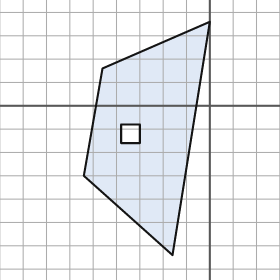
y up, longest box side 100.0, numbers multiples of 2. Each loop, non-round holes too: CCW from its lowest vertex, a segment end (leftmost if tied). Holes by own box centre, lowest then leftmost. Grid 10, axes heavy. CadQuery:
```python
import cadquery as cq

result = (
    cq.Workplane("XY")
    .moveTo(-16.0, -64.0)
    .lineTo(0.0, 36.0)
    .lineTo(-46.0, 16.0)
    .lineTo(-54.0, -30.0)
    .close()
    .moveTo(-38.0, -16.0)
    .lineTo(-30.0, -16.0)
    .lineTo(-30.0, -8.0)
    .lineTo(-38.0, -8.0)
    .close()
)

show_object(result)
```